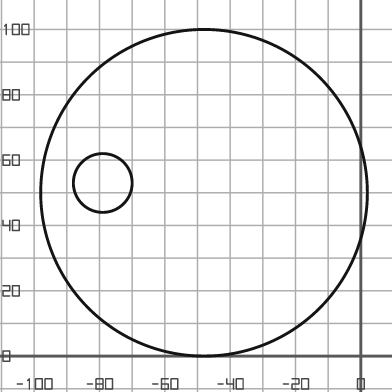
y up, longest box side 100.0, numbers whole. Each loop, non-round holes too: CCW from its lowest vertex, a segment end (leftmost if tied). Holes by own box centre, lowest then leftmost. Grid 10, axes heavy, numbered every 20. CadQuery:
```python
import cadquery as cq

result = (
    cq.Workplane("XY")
    .moveTo(-48.0, 50.0)
    .circle(50.0)
    .moveTo(-79.0, 53.0)
    .circle(9.0)
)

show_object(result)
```